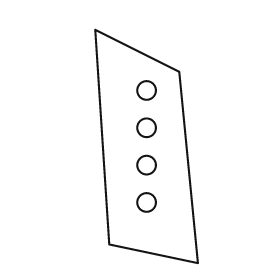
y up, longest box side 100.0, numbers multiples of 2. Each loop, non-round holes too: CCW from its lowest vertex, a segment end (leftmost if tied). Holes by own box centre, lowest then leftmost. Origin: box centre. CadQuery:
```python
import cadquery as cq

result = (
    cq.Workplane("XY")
    .moveTo(22.0, -50.0)
    .lineTo(14.0, 32.0)
    .lineTo(-22.0, 50.0)
    .lineTo(-16.0, -42.0)
    .close()
    .moveTo(0.0, -24.0)
    .circle(4.0)
    .moveTo(0.0, -8.0)
    .circle(4.0)
    .moveTo(0.0, 8.0)
    .circle(4.0)
    .moveTo(0.0, 24.0)
    .circle(4.0)
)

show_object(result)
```